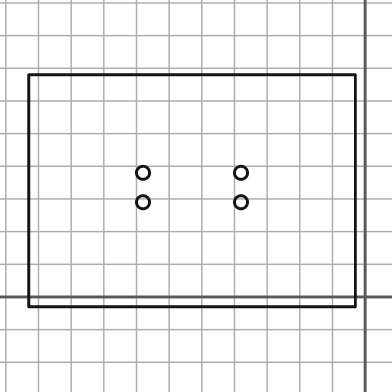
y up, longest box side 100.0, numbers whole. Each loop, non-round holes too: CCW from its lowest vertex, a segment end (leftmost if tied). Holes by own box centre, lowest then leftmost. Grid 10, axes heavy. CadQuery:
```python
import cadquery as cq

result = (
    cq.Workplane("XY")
    .moveTo(-103.0, -3.0)
    .lineTo(-3.0, -3.0)
    .lineTo(-3.0, 68.0)
    .lineTo(-103.0, 68.0)
    .close()
    .moveTo(-68.0, 29.0)
    .circle(2.0)
    .moveTo(-38.0, 29.0)
    .circle(2.0)
    .moveTo(-68.0, 38.0)
    .circle(2.0)
    .moveTo(-38.0, 38.0)
    .circle(2.0)
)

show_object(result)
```